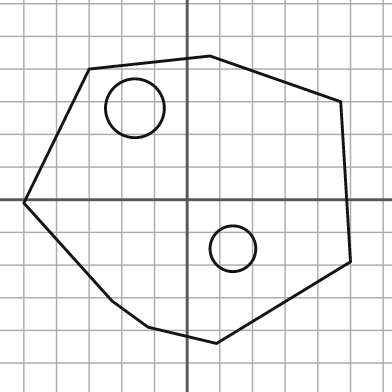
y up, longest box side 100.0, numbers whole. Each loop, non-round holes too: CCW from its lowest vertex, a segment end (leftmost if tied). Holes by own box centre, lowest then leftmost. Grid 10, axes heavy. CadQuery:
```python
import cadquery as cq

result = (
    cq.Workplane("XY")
    .moveTo(9.0, -44.0)
    .lineTo(50.0, -19.0)
    .lineTo(47.0, 30.0)
    .lineTo(7.0, 44.0)
    .lineTo(-30.0, 40.0)
    .lineTo(-50.0, -1.0)
    .lineTo(-23.0, -31.0)
    .lineTo(-12.0, -39.0)
    .close()
    .moveTo(14.0, -15.0)
    .circle(7.0)
    .moveTo(-16.0, 28.0)
    .circle(9.0)
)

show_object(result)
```